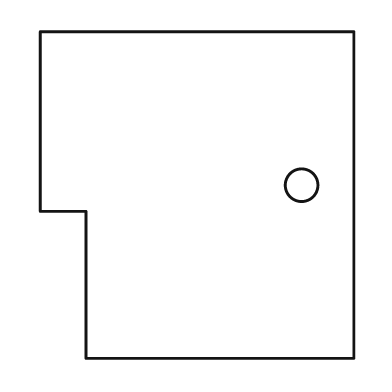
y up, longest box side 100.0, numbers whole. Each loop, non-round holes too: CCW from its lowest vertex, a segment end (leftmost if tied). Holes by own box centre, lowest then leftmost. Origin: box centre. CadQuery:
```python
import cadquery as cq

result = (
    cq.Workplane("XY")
    .moveTo(-34.0, -50.0)
    .lineTo(48.0, -50.0)
    .lineTo(48.0, 50.0)
    .lineTo(-48.0, 50.0)
    .lineTo(-48.0, -5.0)
    .lineTo(-34.0, -5.0)
    .close()
    .moveTo(32.0, 3.0)
    .circle(5.0)
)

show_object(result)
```